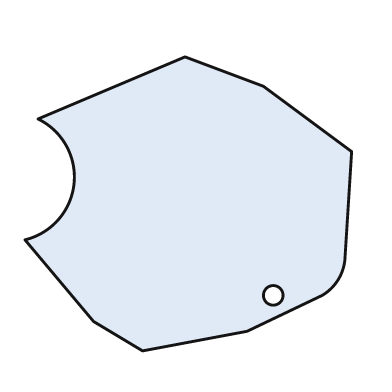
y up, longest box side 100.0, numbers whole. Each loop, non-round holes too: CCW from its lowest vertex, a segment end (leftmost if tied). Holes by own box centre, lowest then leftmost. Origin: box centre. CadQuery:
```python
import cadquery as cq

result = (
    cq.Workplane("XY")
    .moveTo(-14.0, -45.0)
    .lineTo(18.0, -39.0)
    .lineTo(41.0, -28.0)
    .threePointArc((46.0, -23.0), (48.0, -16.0))
    .lineTo(50.0, 16.0)
    .lineTo(23.0, 36.0)
    .lineTo(-1.0, 45.0)
    .lineTo(-46.0, 26.0)
    .threePointArc((-35.0, 6.0), (-50.0, -11.0))
    .lineTo(-29.0, -36.0)
    .close()
    .moveTo(26.0, -28.0)
    .circle(3.0)
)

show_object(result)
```